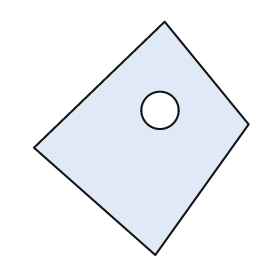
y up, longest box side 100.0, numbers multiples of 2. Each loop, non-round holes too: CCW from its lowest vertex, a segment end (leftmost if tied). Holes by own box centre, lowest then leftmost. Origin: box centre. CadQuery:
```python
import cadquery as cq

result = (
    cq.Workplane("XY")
    .moveTo(6.0, -50.0)
    .lineTo(46.0, 6.0)
    .lineTo(10.0, 50.0)
    .lineTo(-46.0, -4.0)
    .close()
    .moveTo(8.0, 12.0)
    .circle(8.0)
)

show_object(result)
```